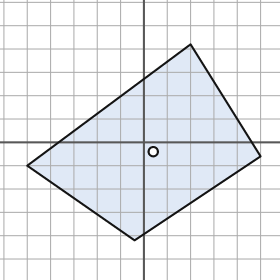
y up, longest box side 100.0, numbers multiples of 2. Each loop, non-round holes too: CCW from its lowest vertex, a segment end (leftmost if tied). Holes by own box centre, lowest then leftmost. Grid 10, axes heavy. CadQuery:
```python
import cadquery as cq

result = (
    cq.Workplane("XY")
    .moveTo(-4.0, -42.0)
    .lineTo(50.0, -6.0)
    .lineTo(20.0, 42.0)
    .lineTo(-50.0, -10.0)
    .close()
    .moveTo(4.0, -4.0)
    .circle(2.0)
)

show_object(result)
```